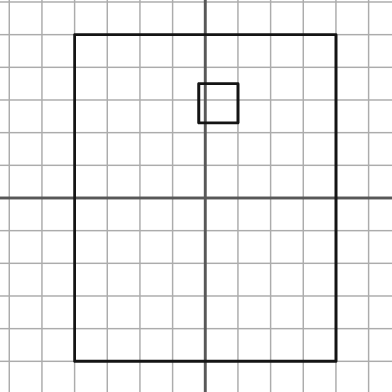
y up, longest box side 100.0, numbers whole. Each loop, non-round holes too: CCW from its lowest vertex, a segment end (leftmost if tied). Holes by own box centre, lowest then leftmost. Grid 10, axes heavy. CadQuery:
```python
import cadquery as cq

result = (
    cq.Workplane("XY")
    .moveTo(-40.0, -50.0)
    .lineTo(40.0, -50.0)
    .lineTo(40.0, 50.0)
    .lineTo(-40.0, 50.0)
    .close()
    .moveTo(-2.0, 23.0)
    .lineTo(10.0, 23.0)
    .lineTo(10.0, 35.0)
    .lineTo(-2.0, 35.0)
    .close()
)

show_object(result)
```